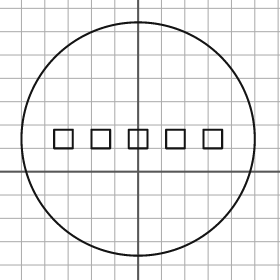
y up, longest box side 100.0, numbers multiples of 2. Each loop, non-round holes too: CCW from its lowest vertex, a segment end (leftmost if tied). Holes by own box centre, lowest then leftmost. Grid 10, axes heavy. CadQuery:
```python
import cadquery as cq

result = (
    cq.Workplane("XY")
    .moveTo(0.0, 14.0)
    .circle(50.0)
    .moveTo(-36.0, 10.0)
    .lineTo(-28.0, 10.0)
    .lineTo(-28.0, 18.0)
    .lineTo(-36.0, 18.0)
    .close()
    .moveTo(-20.0, 10.0)
    .lineTo(-12.0, 10.0)
    .lineTo(-12.0, 18.0)
    .lineTo(-20.0, 18.0)
    .close()
    .moveTo(-4.0, 10.0)
    .lineTo(4.0, 10.0)
    .lineTo(4.0, 18.0)
    .lineTo(-4.0, 18.0)
    .close()
    .moveTo(12.0, 10.0)
    .lineTo(20.0, 10.0)
    .lineTo(20.0, 18.0)
    .lineTo(12.0, 18.0)
    .close()
    .moveTo(28.0, 10.0)
    .lineTo(36.0, 10.0)
    .lineTo(36.0, 18.0)
    .lineTo(28.0, 18.0)
    .close()
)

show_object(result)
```